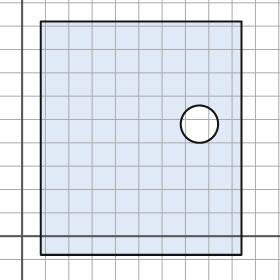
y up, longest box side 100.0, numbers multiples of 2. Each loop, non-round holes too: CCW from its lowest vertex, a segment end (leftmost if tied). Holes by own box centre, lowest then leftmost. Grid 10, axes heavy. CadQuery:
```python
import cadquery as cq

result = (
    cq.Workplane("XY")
    .moveTo(8.0, -8.0)
    .lineTo(94.0, -8.0)
    .lineTo(94.0, 92.0)
    .lineTo(8.0, 92.0)
    .close()
    .moveTo(76.0, 48.0)
    .circle(8.0)
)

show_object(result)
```